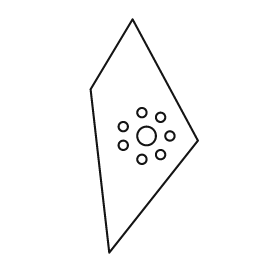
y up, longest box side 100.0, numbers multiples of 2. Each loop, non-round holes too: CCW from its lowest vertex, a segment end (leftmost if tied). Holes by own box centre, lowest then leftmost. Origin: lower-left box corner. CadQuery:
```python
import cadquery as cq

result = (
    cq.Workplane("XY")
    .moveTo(8.0, 0.0)
    .lineTo(46.0, 48.0)
    .lineTo(18.0, 100.0)
    .lineTo(0.0, 70.0)
    .close()
    .moveTo(22.0, 40.0)
    .circle(2.0)
    .moveTo(30.0, 42.0)
    .circle(2.0)
    .moveTo(14.0, 46.0)
    .circle(2.0)
    .moveTo(24.0, 50.0)
    .circle(4.0)
    .moveTo(34.0, 50.0)
    .circle(2.0)
    .moveTo(14.0, 54.0)
    .circle(2.0)
    .moveTo(30.0, 58.0)
    .circle(2.0)
    .moveTo(22.0, 60.0)
    .circle(2.0)
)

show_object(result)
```